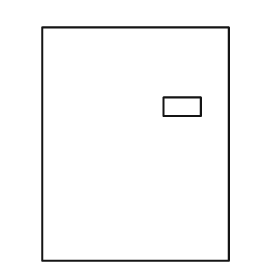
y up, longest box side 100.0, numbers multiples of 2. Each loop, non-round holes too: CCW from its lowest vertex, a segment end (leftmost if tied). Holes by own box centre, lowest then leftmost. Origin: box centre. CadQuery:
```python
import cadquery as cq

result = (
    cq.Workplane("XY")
    .moveTo(-40.0, -50.0)
    .lineTo(40.0, -50.0)
    .lineTo(40.0, 50.0)
    .lineTo(-40.0, 50.0)
    .close()
    .moveTo(12.0, 12.0)
    .lineTo(28.0, 12.0)
    .lineTo(28.0, 20.0)
    .lineTo(12.0, 20.0)
    .close()
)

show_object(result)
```